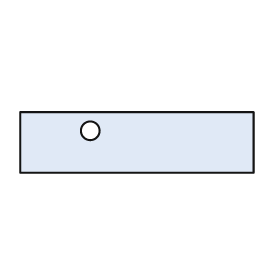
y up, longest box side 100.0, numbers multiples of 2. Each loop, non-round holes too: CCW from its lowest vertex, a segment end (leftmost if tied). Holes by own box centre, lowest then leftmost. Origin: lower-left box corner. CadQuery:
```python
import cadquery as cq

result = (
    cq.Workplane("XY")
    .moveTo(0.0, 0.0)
    .lineTo(100.0, 0.0)
    .lineTo(100.0, 26.0)
    .lineTo(0.0, 26.0)
    .close()
    .moveTo(30.0, 18.0)
    .circle(4.0)
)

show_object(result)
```